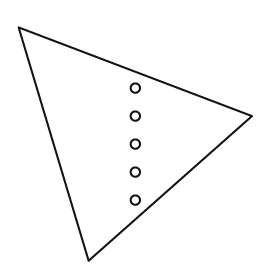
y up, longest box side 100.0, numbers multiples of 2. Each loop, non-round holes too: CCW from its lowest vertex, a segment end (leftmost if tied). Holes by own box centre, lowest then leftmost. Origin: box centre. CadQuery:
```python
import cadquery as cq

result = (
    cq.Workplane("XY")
    .moveTo(-20.0, -50.0)
    .lineTo(50.0, 12.0)
    .lineTo(-50.0, 50.0)
    .close()
    .moveTo(0.0, -24.0)
    .circle(2.0)
    .moveTo(0.0, -12.0)
    .circle(2.0)
    .moveTo(0.0, 0.0)
    .circle(2.0)
    .moveTo(0.0, 12.0)
    .circle(2.0)
    .moveTo(0.0, 24.0)
    .circle(2.0)
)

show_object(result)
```